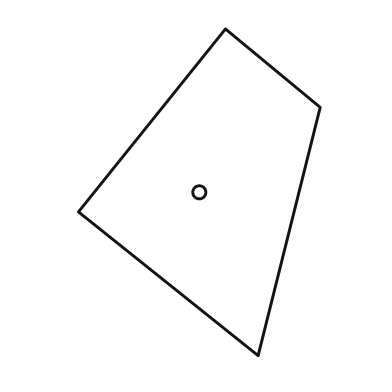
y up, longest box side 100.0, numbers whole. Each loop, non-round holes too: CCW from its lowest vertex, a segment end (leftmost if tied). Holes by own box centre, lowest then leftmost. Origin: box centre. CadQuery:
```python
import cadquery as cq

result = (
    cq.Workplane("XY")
    .moveTo(18.0, -50.0)
    .lineTo(37.0, 26.0)
    .lineTo(8.0, 50.0)
    .lineTo(-37.0, -6.0)
    .close()
    .moveTo(0.0, 0.0)
    .circle(2.0)
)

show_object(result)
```